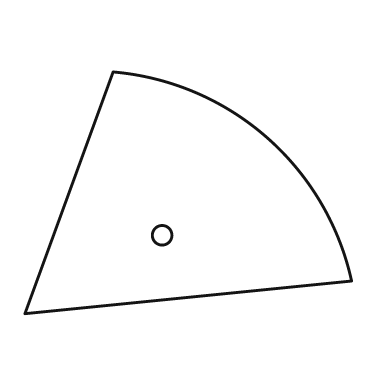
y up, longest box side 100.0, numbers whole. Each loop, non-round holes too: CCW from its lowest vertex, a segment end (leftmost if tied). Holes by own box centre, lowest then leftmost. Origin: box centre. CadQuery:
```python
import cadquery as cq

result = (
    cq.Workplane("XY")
    .moveTo(-50.0, -37.0)
    .lineTo(50.0, -27.0)
    .threePointArc((24.0, 17.0), (-23.0, 37.0))
    .close()
    .moveTo(-8.0, -13.0)
    .circle(3.0)
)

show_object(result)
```